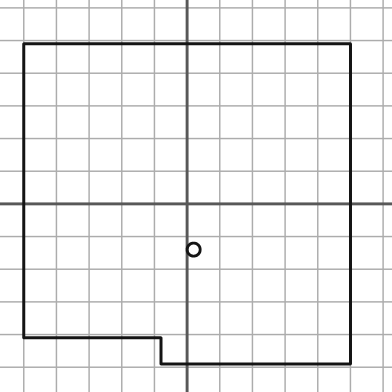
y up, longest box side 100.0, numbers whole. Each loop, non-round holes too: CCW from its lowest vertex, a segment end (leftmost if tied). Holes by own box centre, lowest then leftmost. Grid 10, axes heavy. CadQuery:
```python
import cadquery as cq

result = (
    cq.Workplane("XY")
    .moveTo(-8.0, -49.0)
    .lineTo(50.0, -49.0)
    .lineTo(50.0, 49.0)
    .lineTo(-50.0, 49.0)
    .lineTo(-50.0, -41.0)
    .lineTo(-8.0, -41.0)
    .close()
    .moveTo(2.0, -14.0)
    .circle(2.0)
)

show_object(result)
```